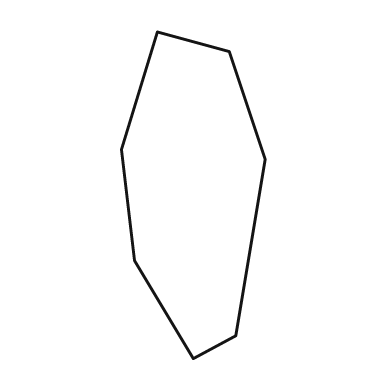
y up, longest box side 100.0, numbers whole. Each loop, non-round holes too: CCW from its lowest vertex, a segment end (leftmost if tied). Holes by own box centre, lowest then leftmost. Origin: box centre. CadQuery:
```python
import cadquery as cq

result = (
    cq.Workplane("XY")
    .moveTo(0.0, -50.0)
    .lineTo(13.0, -43.0)
    .lineTo(22.0, 11.0)
    .lineTo(11.0, 44.0)
    .lineTo(-11.0, 50.0)
    .lineTo(-22.0, 14.0)
    .lineTo(-18.0, -20.0)
    .close()
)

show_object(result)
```